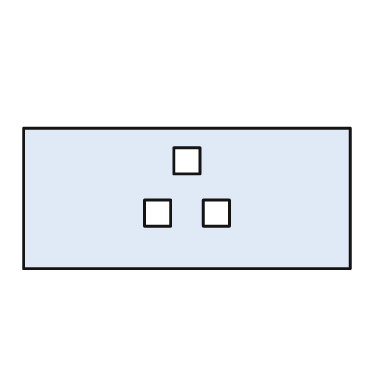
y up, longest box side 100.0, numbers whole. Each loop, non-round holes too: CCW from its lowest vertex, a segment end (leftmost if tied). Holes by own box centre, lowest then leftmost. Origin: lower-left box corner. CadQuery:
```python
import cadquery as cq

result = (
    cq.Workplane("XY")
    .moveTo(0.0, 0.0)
    .lineTo(100.0, 0.0)
    .lineTo(100.0, 43.0)
    .lineTo(0.0, 43.0)
    .close()
    .moveTo(37.0, 13.0)
    .lineTo(45.0, 13.0)
    .lineTo(45.0, 21.0)
    .lineTo(37.0, 21.0)
    .close()
    .moveTo(55.0, 13.0)
    .lineTo(63.0, 13.0)
    .lineTo(63.0, 21.0)
    .lineTo(55.0, 21.0)
    .close()
    .moveTo(46.0, 29.0)
    .lineTo(54.0, 29.0)
    .lineTo(54.0, 37.0)
    .lineTo(46.0, 37.0)
    .close()
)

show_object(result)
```